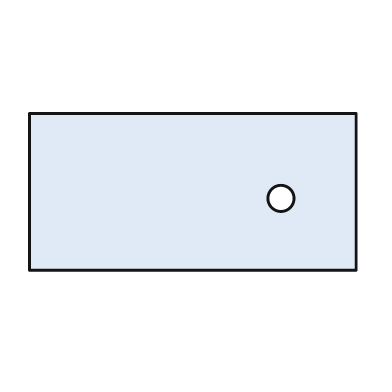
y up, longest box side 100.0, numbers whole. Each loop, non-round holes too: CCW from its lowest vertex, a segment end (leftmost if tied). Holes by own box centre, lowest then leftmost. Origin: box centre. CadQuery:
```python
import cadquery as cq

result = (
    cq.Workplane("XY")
    .moveTo(-50.0, -24.0)
    .lineTo(50.0, -24.0)
    .lineTo(50.0, 24.0)
    .lineTo(-50.0, 24.0)
    .close()
    .moveTo(27.0, -2.0)
    .circle(4.0)
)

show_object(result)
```